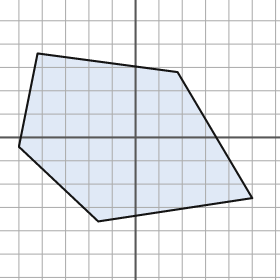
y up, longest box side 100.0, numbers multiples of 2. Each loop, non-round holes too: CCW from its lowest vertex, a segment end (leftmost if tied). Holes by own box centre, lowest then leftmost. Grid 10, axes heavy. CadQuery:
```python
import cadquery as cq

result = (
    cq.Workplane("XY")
    .moveTo(-16.0, -36.0)
    .lineTo(50.0, -26.0)
    .lineTo(18.0, 28.0)
    .lineTo(-42.0, 36.0)
    .lineTo(-50.0, -4.0)
    .close()
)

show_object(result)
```